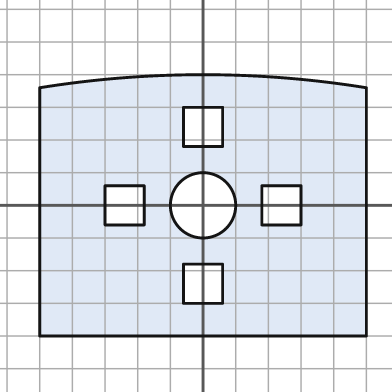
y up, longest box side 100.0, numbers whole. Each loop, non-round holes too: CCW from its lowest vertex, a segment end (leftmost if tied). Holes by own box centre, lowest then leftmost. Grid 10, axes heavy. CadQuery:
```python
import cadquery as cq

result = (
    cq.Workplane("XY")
    .moveTo(-50.0, -40.0)
    .lineTo(50.0, -40.0)
    .lineTo(50.0, 36.0)
    .threePointArc((0.0, 40.0), (-50.0, 36.0))
    .close()
    .moveTo(-6.0, -30.0)
    .lineTo(6.0, -30.0)
    .lineTo(6.0, -18.0)
    .lineTo(-6.0, -18.0)
    .close()
    .moveTo(-30.0, -6.0)
    .lineTo(-18.0, -6.0)
    .lineTo(-18.0, 6.0)
    .lineTo(-30.0, 6.0)
    .close()
    .moveTo(0.0, 0.0)
    .circle(10.0)
    .moveTo(18.0, -6.0)
    .lineTo(30.0, -6.0)
    .lineTo(30.0, 6.0)
    .lineTo(18.0, 6.0)
    .close()
    .moveTo(-6.0, 18.0)
    .lineTo(6.0, 18.0)
    .lineTo(6.0, 30.0)
    .lineTo(-6.0, 30.0)
    .close()
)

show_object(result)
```